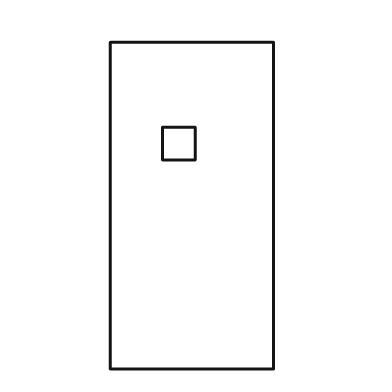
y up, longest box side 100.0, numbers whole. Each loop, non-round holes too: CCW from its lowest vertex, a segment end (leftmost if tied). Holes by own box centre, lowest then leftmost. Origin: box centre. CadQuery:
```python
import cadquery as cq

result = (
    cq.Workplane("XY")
    .moveTo(-25.0, -50.0)
    .lineTo(25.0, -50.0)
    .lineTo(25.0, 50.0)
    .lineTo(-25.0, 50.0)
    .close()
    .moveTo(-9.0, 14.0)
    .lineTo(1.0, 14.0)
    .lineTo(1.0, 24.0)
    .lineTo(-9.0, 24.0)
    .close()
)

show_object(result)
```